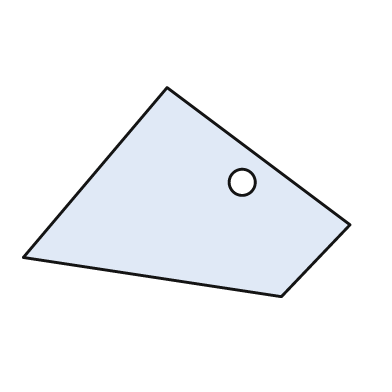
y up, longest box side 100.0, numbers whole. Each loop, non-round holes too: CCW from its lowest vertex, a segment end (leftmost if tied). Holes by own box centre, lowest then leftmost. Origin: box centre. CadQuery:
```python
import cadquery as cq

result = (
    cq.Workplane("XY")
    .moveTo(29.0, -32.0)
    .lineTo(50.0, -10.0)
    .lineTo(-6.0, 32.0)
    .lineTo(-50.0, -20.0)
    .close()
    .moveTo(17.0, 3.0)
    .circle(4.0)
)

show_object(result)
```